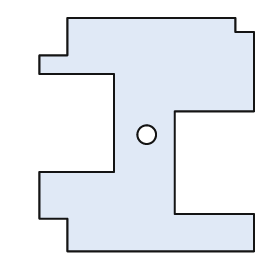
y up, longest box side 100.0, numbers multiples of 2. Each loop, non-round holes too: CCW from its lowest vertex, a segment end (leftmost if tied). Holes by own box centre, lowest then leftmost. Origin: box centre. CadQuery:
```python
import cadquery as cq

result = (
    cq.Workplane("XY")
    .moveTo(-34.0, -50.0)
    .lineTo(46.0, -50.0)
    .lineTo(46.0, -34.0)
    .lineTo(12.0, -34.0)
    .lineTo(12.0, 10.0)
    .lineTo(46.0, 10.0)
    .lineTo(46.0, 44.0)
    .lineTo(38.0, 44.0)
    .lineTo(38.0, 50.0)
    .lineTo(-34.0, 50.0)
    .lineTo(-34.0, 34.0)
    .lineTo(-46.0, 34.0)
    .lineTo(-46.0, 26.0)
    .lineTo(-14.0, 26.0)
    .lineTo(-14.0, -16.0)
    .lineTo(-46.0, -16.0)
    .lineTo(-46.0, -36.0)
    .lineTo(-34.0, -36.0)
    .close()
    .moveTo(0.0, 0.0)
    .circle(4.0)
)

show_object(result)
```